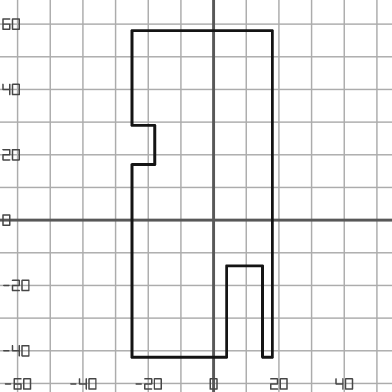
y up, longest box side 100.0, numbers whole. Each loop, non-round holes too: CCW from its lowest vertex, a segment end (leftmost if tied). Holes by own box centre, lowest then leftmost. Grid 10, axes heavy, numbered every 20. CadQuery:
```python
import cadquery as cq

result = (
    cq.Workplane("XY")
    .moveTo(-25.0, -42.0)
    .lineTo(4.0, -42.0)
    .lineTo(4.0, -14.0)
    .lineTo(15.0, -14.0)
    .lineTo(15.0, -42.0)
    .lineTo(18.0, -42.0)
    .lineTo(18.0, 58.0)
    .lineTo(-25.0, 58.0)
    .lineTo(-25.0, 29.0)
    .lineTo(-18.0, 29.0)
    .lineTo(-18.0, 17.0)
    .lineTo(-25.0, 17.0)
    .close()
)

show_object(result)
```